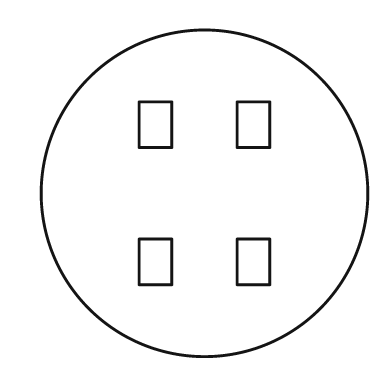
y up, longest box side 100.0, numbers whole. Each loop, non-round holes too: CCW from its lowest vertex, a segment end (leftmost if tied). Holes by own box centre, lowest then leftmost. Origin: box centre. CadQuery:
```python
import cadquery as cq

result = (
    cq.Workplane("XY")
    .moveTo(0.0, 0.0)
    .circle(50.0)
    .moveTo(-20.0, -28.0)
    .lineTo(-10.0, -28.0)
    .lineTo(-10.0, -14.0)
    .lineTo(-20.0, -14.0)
    .close()
    .moveTo(10.0, -28.0)
    .lineTo(20.0, -28.0)
    .lineTo(20.0, -14.0)
    .lineTo(10.0, -14.0)
    .close()
    .moveTo(-20.0, 14.0)
    .lineTo(-10.0, 14.0)
    .lineTo(-10.0, 28.0)
    .lineTo(-20.0, 28.0)
    .close()
    .moveTo(10.0, 14.0)
    .lineTo(20.0, 14.0)
    .lineTo(20.0, 28.0)
    .lineTo(10.0, 28.0)
    .close()
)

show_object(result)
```